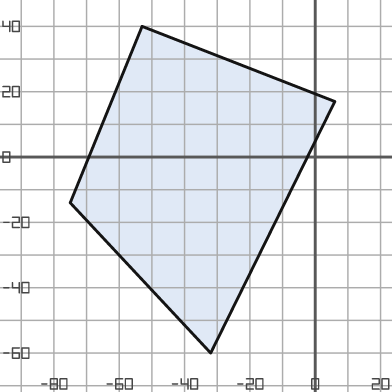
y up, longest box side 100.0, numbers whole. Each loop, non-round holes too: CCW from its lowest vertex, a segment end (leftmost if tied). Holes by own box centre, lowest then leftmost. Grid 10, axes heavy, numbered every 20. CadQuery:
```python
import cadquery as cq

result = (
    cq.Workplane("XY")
    .moveTo(-32.0, -60.0)
    .lineTo(6.0, 17.0)
    .lineTo(-53.0, 40.0)
    .lineTo(-75.0, -14.0)
    .close()
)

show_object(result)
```